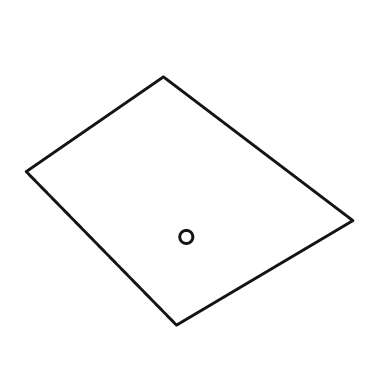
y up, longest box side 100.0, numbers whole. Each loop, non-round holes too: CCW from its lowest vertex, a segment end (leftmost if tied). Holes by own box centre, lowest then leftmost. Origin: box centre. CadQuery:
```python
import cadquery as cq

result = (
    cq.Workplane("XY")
    .moveTo(-4.0, -38.0)
    .lineTo(50.0, -6.0)
    .lineTo(-8.0, 38.0)
    .lineTo(-50.0, 9.0)
    .close()
    .moveTo(-1.0, -11.0)
    .circle(2.0)
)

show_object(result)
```